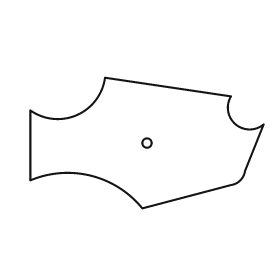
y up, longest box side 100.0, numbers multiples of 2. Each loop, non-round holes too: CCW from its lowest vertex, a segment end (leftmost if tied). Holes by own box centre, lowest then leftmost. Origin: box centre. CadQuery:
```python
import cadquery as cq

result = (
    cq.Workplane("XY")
    .moveTo(-2.0, -28.0)
    .lineTo(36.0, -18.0)
    .threePointArc((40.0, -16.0), (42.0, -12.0))
    .lineTo(50.0, 8.0)
    .threePointArc((38.0, 8.0), (36.0, 20.0))
    .lineTo(-18.0, 28.0)
    .threePointArc((-30.0, 12.0), (-50.0, 14.0))
    .lineTo(-50.0, -16.0)
    .threePointArc((-24.0, -14.0), (-2.0, -28.0))
    .close()
    .moveTo(0.0, 0.0)
    .circle(2.0)
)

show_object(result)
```